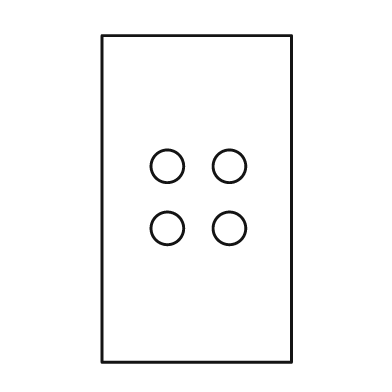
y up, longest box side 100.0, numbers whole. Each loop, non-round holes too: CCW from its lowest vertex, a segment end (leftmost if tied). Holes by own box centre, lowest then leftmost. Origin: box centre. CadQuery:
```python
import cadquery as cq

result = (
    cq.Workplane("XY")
    .moveTo(-29.0, -50.0)
    .lineTo(29.0, -50.0)
    .lineTo(29.0, 50.0)
    .lineTo(-29.0, 50.0)
    .close()
    .moveTo(-9.0, -9.0)
    .circle(5.0)
    .moveTo(10.0, -9.0)
    .circle(5.0)
    .moveTo(-9.0, 10.0)
    .circle(5.0)
    .moveTo(10.0, 10.0)
    .circle(5.0)
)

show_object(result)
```